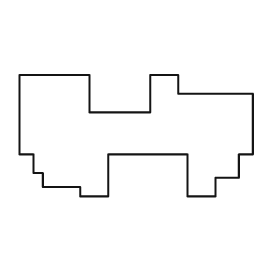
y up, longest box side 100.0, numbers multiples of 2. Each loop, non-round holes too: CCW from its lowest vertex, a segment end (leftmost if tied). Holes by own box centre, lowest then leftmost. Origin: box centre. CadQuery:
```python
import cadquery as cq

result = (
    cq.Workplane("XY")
    .moveTo(-24.0, -26.0)
    .lineTo(-12.0, -26.0)
    .lineTo(-12.0, -8.0)
    .lineTo(22.0, -8.0)
    .lineTo(22.0, -26.0)
    .lineTo(34.0, -26.0)
    .lineTo(34.0, -18.0)
    .lineTo(44.0, -18.0)
    .lineTo(44.0, -8.0)
    .lineTo(50.0, -8.0)
    .lineTo(50.0, 18.0)
    .lineTo(18.0, 18.0)
    .lineTo(18.0, 26.0)
    .lineTo(6.0, 26.0)
    .lineTo(6.0, 10.0)
    .lineTo(-20.0, 10.0)
    .lineTo(-20.0, 26.0)
    .lineTo(-50.0, 26.0)
    .lineTo(-50.0, -8.0)
    .lineTo(-44.0, -8.0)
    .lineTo(-44.0, -16.0)
    .lineTo(-40.0, -16.0)
    .lineTo(-40.0, -22.0)
    .lineTo(-24.0, -22.0)
    .close()
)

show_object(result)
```